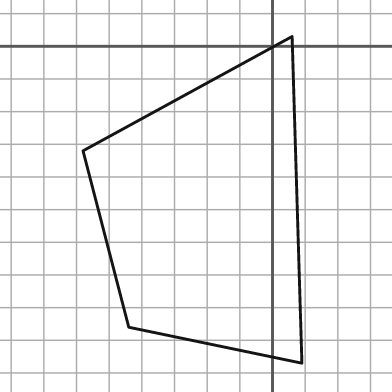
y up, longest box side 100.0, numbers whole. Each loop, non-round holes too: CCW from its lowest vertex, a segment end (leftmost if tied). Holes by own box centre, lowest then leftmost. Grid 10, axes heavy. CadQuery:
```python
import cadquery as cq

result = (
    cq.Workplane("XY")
    .moveTo(9.0, -97.0)
    .lineTo(6.0, 3.0)
    .lineTo(-58.0, -32.0)
    .lineTo(-44.0, -86.0)
    .close()
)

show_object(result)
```